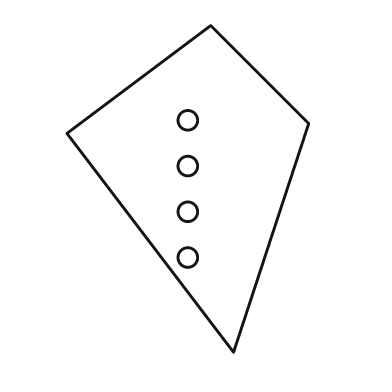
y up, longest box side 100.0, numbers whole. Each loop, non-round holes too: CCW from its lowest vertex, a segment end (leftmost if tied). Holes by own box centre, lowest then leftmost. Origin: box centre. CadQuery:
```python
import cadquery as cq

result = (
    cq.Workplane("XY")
    .moveTo(14.0, -50.0)
    .lineTo(37.0, 20.0)
    .lineTo(7.0, 50.0)
    .lineTo(-37.0, 17.0)
    .close()
    .moveTo(0.0, -21.0)
    .circle(3.0)
    .moveTo(0.0, -7.0)
    .circle(3.0)
    .moveTo(0.0, 7.0)
    .circle(3.0)
    .moveTo(0.0, 21.0)
    .circle(3.0)
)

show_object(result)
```